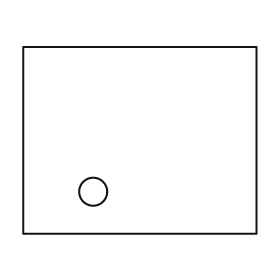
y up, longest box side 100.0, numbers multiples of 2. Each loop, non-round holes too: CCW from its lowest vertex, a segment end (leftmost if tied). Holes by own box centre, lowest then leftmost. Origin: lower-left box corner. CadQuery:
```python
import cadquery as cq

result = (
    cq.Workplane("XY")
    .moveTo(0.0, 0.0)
    .lineTo(100.0, 0.0)
    .lineTo(100.0, 80.0)
    .lineTo(0.0, 80.0)
    .close()
    .moveTo(30.0, 18.0)
    .circle(6.0)
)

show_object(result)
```